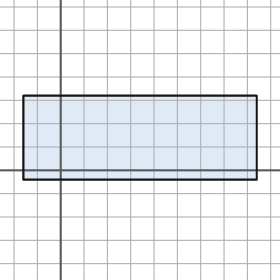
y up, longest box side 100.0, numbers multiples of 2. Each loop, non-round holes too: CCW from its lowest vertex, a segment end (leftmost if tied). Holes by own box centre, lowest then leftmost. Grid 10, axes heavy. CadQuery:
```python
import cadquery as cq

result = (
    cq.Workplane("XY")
    .moveTo(-16.0, -4.0)
    .lineTo(84.0, -4.0)
    .lineTo(84.0, 32.0)
    .lineTo(-16.0, 32.0)
    .close()
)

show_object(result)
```